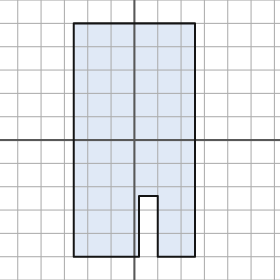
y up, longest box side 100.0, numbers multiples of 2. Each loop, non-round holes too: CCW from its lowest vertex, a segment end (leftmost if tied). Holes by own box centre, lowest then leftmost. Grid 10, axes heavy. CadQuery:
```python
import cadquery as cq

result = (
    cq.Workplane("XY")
    .moveTo(-26.0, -50.0)
    .lineTo(2.0, -50.0)
    .lineTo(2.0, -24.0)
    .lineTo(10.0, -24.0)
    .lineTo(10.0, -50.0)
    .lineTo(26.0, -50.0)
    .lineTo(26.0, 50.0)
    .lineTo(-26.0, 50.0)
    .close()
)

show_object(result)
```